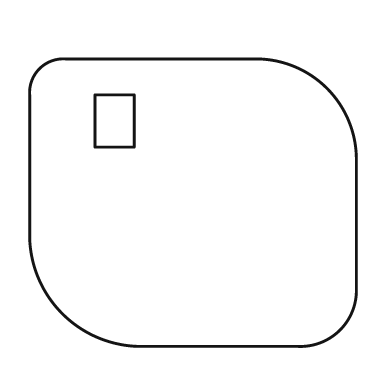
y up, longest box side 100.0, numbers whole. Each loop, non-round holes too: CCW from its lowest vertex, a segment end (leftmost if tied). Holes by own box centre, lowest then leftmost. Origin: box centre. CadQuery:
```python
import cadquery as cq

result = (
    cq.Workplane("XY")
    .moveTo(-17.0, -44.0)
    .lineTo(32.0, -44.0)
    .threePointArc((45.0, -39.0), (50.0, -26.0))
    .lineTo(50.0, 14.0)
    .threePointArc((41.0, 35.0), (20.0, 44.0))
    .lineTo(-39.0, 44.0)
    .threePointArc((-47.0, 41.0), (-50.0, 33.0))
    .lineTo(-50.0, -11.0)
    .threePointArc((-40.0, -34.0), (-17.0, -44.0))
    .close()
    .moveTo(-30.0, 17.0)
    .lineTo(-18.0, 17.0)
    .lineTo(-18.0, 33.0)
    .lineTo(-30.0, 33.0)
    .close()
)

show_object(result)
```